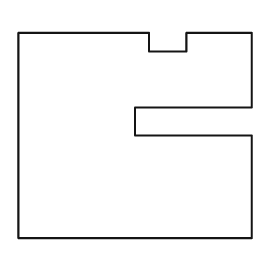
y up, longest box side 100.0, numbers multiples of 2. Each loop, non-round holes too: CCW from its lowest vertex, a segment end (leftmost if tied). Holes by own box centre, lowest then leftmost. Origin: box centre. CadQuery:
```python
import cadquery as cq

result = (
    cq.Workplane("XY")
    .moveTo(-50.0, -44.0)
    .lineTo(50.0, -44.0)
    .lineTo(50.0, 0.0)
    .lineTo(0.0, 0.0)
    .lineTo(0.0, 12.0)
    .lineTo(50.0, 12.0)
    .lineTo(50.0, 44.0)
    .lineTo(22.0, 44.0)
    .lineTo(22.0, 36.0)
    .lineTo(6.0, 36.0)
    .lineTo(6.0, 44.0)
    .lineTo(-50.0, 44.0)
    .close()
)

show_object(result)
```